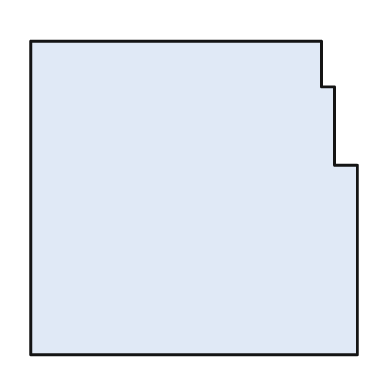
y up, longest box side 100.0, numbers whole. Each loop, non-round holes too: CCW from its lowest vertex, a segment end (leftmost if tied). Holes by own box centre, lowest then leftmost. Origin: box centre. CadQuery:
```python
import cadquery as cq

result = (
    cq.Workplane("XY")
    .moveTo(-50.0, -48.0)
    .lineTo(50.0, -48.0)
    .lineTo(50.0, 10.0)
    .lineTo(43.0, 10.0)
    .lineTo(43.0, 34.0)
    .lineTo(39.0, 34.0)
    .lineTo(39.0, 48.0)
    .lineTo(-50.0, 48.0)
    .close()
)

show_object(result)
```